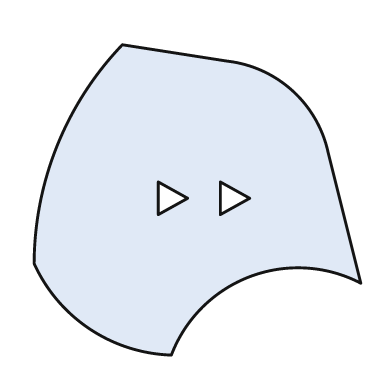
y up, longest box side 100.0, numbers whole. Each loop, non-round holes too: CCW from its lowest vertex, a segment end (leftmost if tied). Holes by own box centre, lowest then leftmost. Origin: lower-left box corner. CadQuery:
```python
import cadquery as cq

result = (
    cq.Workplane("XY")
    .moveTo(42.0, 0.0)
    .threePointArc((66.0, 24.0), (100.0, 22.0))
    .lineTo(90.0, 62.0)
    .threePointArc((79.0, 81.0), (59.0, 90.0))
    .lineTo(27.0, 95.0)
    .threePointArc((7.0, 64.0), (0.0, 28.0))
    .threePointArc((17.0, 8.0), (42.0, 0.0))
    .close()
    .moveTo(38.0, 43.0)
    .lineTo(47.0, 48.0)
    .lineTo(38.0, 53.0)
    .close()
    .moveTo(57.0, 43.0)
    .lineTo(66.0, 48.0)
    .lineTo(57.0, 53.0)
    .close()
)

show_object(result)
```